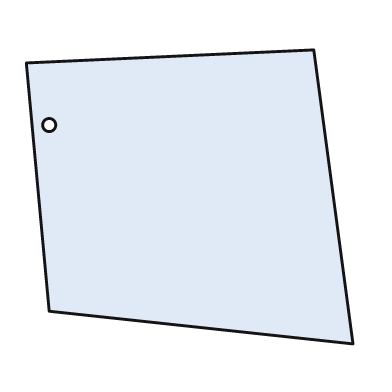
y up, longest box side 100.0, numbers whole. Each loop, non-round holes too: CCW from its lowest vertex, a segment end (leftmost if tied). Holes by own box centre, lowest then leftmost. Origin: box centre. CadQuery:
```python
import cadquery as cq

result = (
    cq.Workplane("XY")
    .moveTo(50.0, -45.0)
    .lineTo(38.0, 45.0)
    .lineTo(-50.0, 41.0)
    .lineTo(-43.0, -35.0)
    .close()
    .moveTo(-43.0, 22.0)
    .circle(2.0)
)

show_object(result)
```